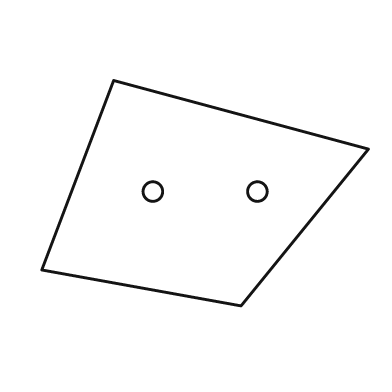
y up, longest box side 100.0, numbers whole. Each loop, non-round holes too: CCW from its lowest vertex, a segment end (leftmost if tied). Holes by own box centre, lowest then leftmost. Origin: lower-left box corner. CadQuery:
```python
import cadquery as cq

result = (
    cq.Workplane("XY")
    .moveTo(61.0, 0.0)
    .lineTo(100.0, 48.0)
    .lineTo(22.0, 69.0)
    .lineTo(0.0, 11.0)
    .close()
    .moveTo(34.0, 35.0)
    .circle(3.0)
    .moveTo(66.0, 35.0)
    .circle(3.0)
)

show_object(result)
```